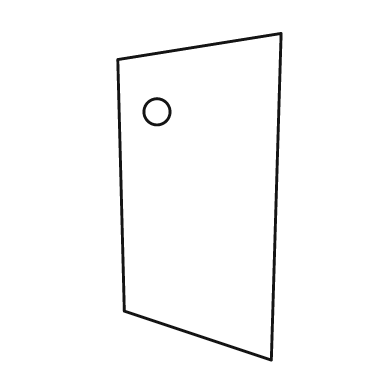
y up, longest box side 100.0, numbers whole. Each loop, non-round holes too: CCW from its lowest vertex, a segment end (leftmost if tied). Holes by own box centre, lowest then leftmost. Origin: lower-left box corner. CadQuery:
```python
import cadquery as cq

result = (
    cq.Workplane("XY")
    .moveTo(47.0, 0.0)
    .lineTo(50.0, 100.0)
    .lineTo(0.0, 92.0)
    .lineTo(2.0, 15.0)
    .close()
    .moveTo(12.0, 76.0)
    .circle(4.0)
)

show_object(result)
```